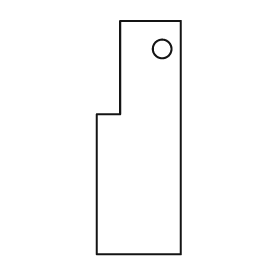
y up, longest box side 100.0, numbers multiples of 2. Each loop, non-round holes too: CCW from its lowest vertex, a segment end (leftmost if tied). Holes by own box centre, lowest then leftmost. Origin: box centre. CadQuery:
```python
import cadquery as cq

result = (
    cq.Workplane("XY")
    .moveTo(-18.0, -50.0)
    .lineTo(18.0, -50.0)
    .lineTo(18.0, 50.0)
    .lineTo(-8.0, 50.0)
    .lineTo(-8.0, 10.0)
    .lineTo(-18.0, 10.0)
    .close()
    .moveTo(10.0, 38.0)
    .circle(4.0)
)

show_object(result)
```